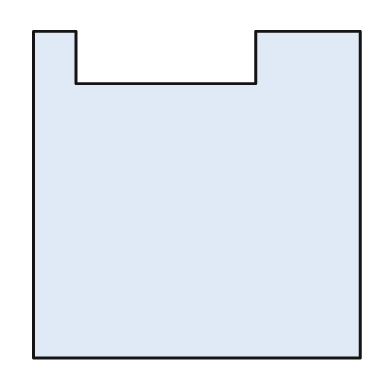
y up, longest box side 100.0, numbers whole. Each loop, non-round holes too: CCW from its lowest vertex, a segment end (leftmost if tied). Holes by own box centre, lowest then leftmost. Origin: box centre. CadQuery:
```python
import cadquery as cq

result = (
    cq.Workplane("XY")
    .moveTo(-50.0, -50.0)
    .lineTo(50.0, -50.0)
    .lineTo(50.0, 50.0)
    .lineTo(18.0, 50.0)
    .lineTo(18.0, 34.0)
    .lineTo(-37.0, 34.0)
    .lineTo(-37.0, 50.0)
    .lineTo(-50.0, 50.0)
    .close()
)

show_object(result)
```